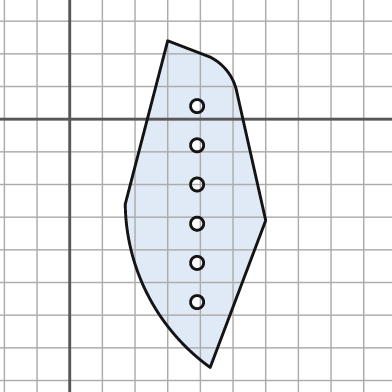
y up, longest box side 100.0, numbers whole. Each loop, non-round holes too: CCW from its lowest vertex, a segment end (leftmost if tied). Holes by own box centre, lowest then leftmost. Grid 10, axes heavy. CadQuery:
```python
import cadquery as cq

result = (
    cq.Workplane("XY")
    .moveTo(43.0, -76.0)
    .lineTo(60.0, -31.0)
    .lineTo(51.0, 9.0)
    .threePointArc((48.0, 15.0), (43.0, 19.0))
    .lineTo(30.0, 24.0)
    .lineTo(17.0, -26.0)
    .threePointArc((24.0, -54.0), (43.0, -76.0))
    .close()
    .moveTo(39.0, -56.0)
    .circle(2.0)
    .moveTo(39.0, -44.0)
    .circle(2.0)
    .moveTo(39.0, -32.0)
    .circle(2.0)
    .moveTo(39.0, -20.0)
    .circle(2.0)
    .moveTo(39.0, -8.0)
    .circle(2.0)
    .moveTo(39.0, 4.0)
    .circle(2.0)
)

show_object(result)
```